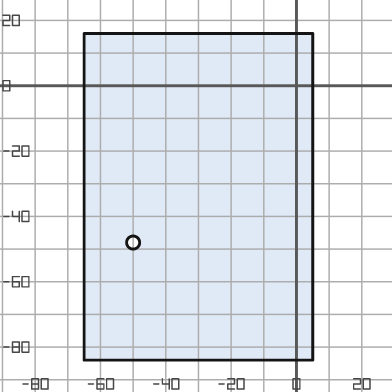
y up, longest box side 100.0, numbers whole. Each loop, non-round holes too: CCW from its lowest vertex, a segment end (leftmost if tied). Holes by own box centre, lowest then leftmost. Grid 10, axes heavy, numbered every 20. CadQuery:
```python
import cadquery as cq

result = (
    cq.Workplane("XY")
    .moveTo(-65.0, -84.0)
    .lineTo(5.0, -84.0)
    .lineTo(5.0, 16.0)
    .lineTo(-65.0, 16.0)
    .close()
    .moveTo(-50.0, -48.0)
    .circle(2.0)
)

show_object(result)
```